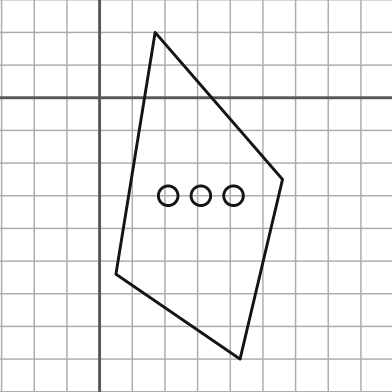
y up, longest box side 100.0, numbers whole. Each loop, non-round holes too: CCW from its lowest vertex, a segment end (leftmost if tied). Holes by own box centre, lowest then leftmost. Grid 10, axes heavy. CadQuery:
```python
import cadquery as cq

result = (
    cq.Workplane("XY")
    .moveTo(43.0, -80.0)
    .lineTo(56.0, -25.0)
    .lineTo(17.0, 20.0)
    .lineTo(5.0, -54.0)
    .close()
    .moveTo(21.0, -30.0)
    .circle(3.0)
    .moveTo(31.0, -30.0)
    .circle(3.0)
    .moveTo(41.0, -30.0)
    .circle(3.0)
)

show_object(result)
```